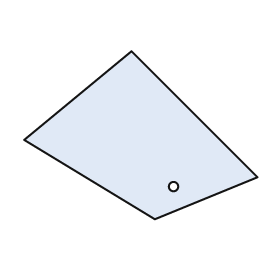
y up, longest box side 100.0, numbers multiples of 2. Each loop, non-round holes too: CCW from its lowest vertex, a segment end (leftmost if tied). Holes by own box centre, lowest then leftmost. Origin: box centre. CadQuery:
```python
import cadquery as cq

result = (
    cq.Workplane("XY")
    .moveTo(6.0, -36.0)
    .lineTo(50.0, -18.0)
    .lineTo(-4.0, 36.0)
    .lineTo(-50.0, -2.0)
    .close()
    .moveTo(14.0, -22.0)
    .circle(2.0)
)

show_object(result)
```